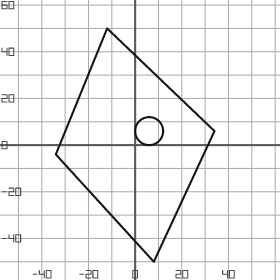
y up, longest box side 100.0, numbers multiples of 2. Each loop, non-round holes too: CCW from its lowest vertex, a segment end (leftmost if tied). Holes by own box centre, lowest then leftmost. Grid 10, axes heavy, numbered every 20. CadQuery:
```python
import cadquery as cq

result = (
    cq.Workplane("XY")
    .moveTo(8.0, -50.0)
    .lineTo(34.0, 6.0)
    .lineTo(-12.0, 50.0)
    .lineTo(-34.0, -4.0)
    .close()
    .moveTo(6.0, 6.0)
    .circle(6.0)
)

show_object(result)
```